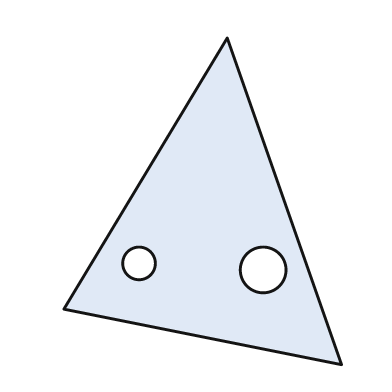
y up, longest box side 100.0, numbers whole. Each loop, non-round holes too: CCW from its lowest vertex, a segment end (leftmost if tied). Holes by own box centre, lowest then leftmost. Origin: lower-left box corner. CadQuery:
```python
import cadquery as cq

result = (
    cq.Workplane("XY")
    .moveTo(85.0, 0.0)
    .lineTo(50.0, 100.0)
    .lineTo(0.0, 17.0)
    .close()
    .moveTo(61.0, 29.0)
    .circle(7.0)
    .moveTo(23.0, 31.0)
    .circle(5.0)
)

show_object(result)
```